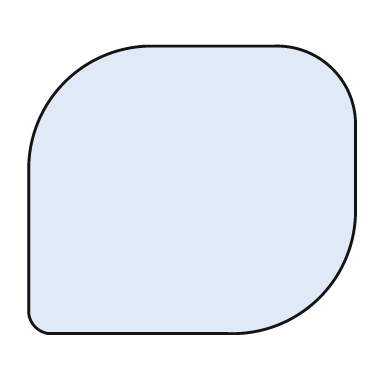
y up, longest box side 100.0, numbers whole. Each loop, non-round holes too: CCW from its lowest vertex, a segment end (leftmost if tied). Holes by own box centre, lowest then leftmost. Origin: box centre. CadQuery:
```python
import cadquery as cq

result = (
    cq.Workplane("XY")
    .moveTo(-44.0, -44.0)
    .lineTo(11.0, -44.0)
    .threePointArc((39.0, -33.0), (50.0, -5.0))
    .lineTo(50.0, 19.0)
    .threePointArc((43.0, 37.0), (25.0, 44.0))
    .lineTo(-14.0, 44.0)
    .threePointArc((-39.0, 33.0), (-50.0, 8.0))
    .lineTo(-50.0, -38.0)
    .threePointArc((-48.0, -42.0), (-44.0, -44.0))
    .close()
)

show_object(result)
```